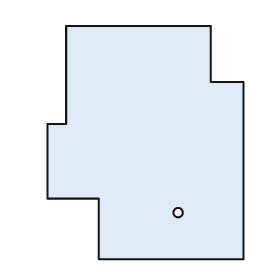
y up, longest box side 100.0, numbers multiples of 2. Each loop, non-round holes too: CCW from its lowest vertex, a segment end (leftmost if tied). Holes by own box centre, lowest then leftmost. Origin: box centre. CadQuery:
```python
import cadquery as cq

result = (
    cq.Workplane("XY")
    .moveTo(-20.0, -50.0)
    .lineTo(42.0, -50.0)
    .lineTo(42.0, 26.0)
    .lineTo(28.0, 26.0)
    .lineTo(28.0, 50.0)
    .lineTo(-34.0, 50.0)
    .lineTo(-34.0, 8.0)
    .lineTo(-42.0, 8.0)
    .lineTo(-42.0, -24.0)
    .lineTo(-20.0, -24.0)
    .close()
    .moveTo(14.0, -30.0)
    .circle(2.0)
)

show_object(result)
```